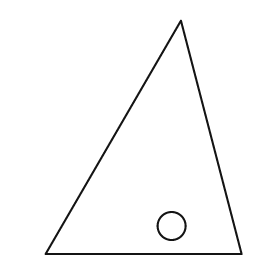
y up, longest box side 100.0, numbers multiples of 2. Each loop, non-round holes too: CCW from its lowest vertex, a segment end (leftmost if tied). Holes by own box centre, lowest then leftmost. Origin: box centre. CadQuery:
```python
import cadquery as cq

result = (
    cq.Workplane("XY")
    .moveTo(-42.0, -50.0)
    .lineTo(42.0, -50.0)
    .lineTo(16.0, 50.0)
    .close()
    .moveTo(12.0, -38.0)
    .circle(6.0)
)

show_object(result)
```